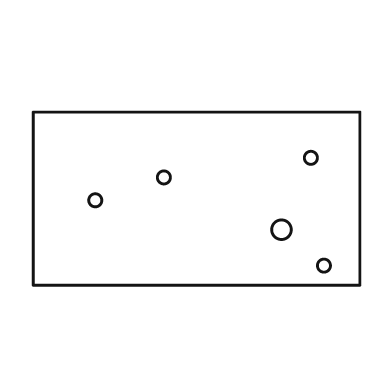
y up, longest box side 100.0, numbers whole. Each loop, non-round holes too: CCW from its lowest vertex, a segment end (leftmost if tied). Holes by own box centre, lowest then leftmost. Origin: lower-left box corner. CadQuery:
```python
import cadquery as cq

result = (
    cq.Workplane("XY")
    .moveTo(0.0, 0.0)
    .lineTo(100.0, 0.0)
    .lineTo(100.0, 53.0)
    .lineTo(0.0, 53.0)
    .close()
    .moveTo(89.0, 6.0)
    .circle(2.0)
    .moveTo(76.0, 17.0)
    .circle(3.0)
    .moveTo(19.0, 26.0)
    .circle(2.0)
    .moveTo(40.0, 33.0)
    .circle(2.0)
    .moveTo(85.0, 39.0)
    .circle(2.0)
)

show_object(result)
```